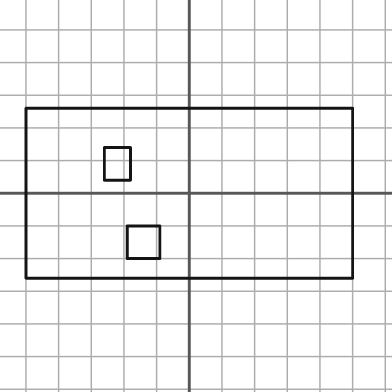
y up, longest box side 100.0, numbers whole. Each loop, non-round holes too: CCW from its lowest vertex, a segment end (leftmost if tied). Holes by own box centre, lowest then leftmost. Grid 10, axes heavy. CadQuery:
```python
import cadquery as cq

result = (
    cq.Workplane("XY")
    .moveTo(-50.0, -26.0)
    .lineTo(50.0, -26.0)
    .lineTo(50.0, 26.0)
    .lineTo(-50.0, 26.0)
    .close()
    .moveTo(-19.0, -20.0)
    .lineTo(-9.0, -20.0)
    .lineTo(-9.0, -10.0)
    .lineTo(-19.0, -10.0)
    .close()
    .moveTo(-26.0, 4.0)
    .lineTo(-18.0, 4.0)
    .lineTo(-18.0, 14.0)
    .lineTo(-26.0, 14.0)
    .close()
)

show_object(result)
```